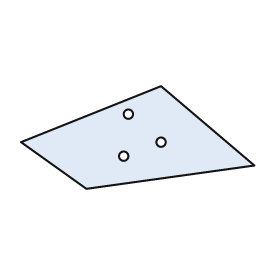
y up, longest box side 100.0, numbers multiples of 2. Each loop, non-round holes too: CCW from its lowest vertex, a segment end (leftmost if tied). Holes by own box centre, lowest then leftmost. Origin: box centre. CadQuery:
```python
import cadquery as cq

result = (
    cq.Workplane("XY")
    .moveTo(-22.0, -22.0)
    .lineTo(50.0, -12.0)
    .lineTo(10.0, 22.0)
    .lineTo(-50.0, -2.0)
    .close()
    .moveTo(-6.0, -8.0)
    .circle(2.0)
    .moveTo(10.0, -2.0)
    .circle(2.0)
    .moveTo(-4.0, 10.0)
    .circle(2.0)
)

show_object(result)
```